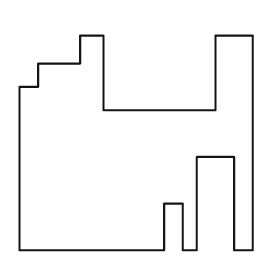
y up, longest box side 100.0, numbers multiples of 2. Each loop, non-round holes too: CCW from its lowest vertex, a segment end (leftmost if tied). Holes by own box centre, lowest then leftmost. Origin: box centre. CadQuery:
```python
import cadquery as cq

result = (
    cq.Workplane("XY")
    .moveTo(-50.0, -46.0)
    .lineTo(12.0, -46.0)
    .lineTo(12.0, -26.0)
    .lineTo(20.0, -26.0)
    .lineTo(20.0, -46.0)
    .lineTo(26.0, -46.0)
    .lineTo(26.0, -6.0)
    .lineTo(42.0, -6.0)
    .lineTo(42.0, -46.0)
    .lineTo(50.0, -46.0)
    .lineTo(50.0, 46.0)
    .lineTo(34.0, 46.0)
    .lineTo(34.0, 14.0)
    .lineTo(-14.0, 14.0)
    .lineTo(-14.0, 46.0)
    .lineTo(-24.0, 46.0)
    .lineTo(-24.0, 34.0)
    .lineTo(-42.0, 34.0)
    .lineTo(-42.0, 24.0)
    .lineTo(-50.0, 24.0)
    .close()
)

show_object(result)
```